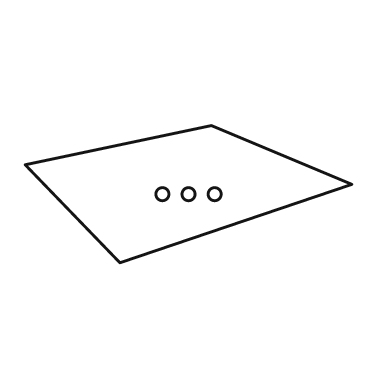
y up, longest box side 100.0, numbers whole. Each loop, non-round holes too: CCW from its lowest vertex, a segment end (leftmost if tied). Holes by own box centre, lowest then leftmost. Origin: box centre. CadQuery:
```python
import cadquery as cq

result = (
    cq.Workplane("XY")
    .moveTo(-21.0, -21.0)
    .lineTo(50.0, 3.0)
    .lineTo(7.0, 21.0)
    .lineTo(-50.0, 9.0)
    .close()
    .moveTo(-8.0, 0.0)
    .circle(2.0)
    .moveTo(0.0, 0.0)
    .circle(2.0)
    .moveTo(8.0, 0.0)
    .circle(2.0)
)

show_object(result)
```